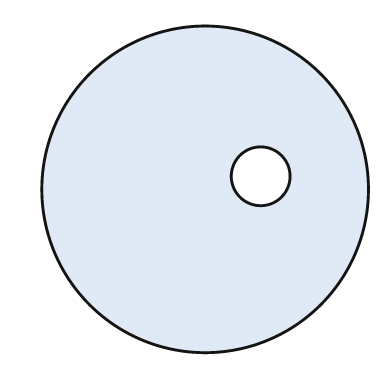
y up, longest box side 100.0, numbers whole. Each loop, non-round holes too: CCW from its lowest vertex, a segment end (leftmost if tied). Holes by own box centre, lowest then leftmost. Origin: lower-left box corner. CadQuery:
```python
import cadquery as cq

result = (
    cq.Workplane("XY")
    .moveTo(50.0, 50.0)
    .circle(50.0)
    .moveTo(67.0, 54.0)
    .circle(9.0)
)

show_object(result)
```